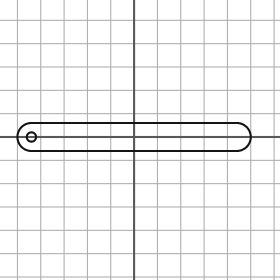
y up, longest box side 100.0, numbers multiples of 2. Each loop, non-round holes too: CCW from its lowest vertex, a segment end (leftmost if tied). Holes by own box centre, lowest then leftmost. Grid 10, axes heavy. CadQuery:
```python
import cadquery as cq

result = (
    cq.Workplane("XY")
    .moveTo(-44.0, -6.0)
    .lineTo(44.0, -6.0)
    .threePointArc((50.0, 0.0), (44.0, 6.0))
    .lineTo(-44.0, 6.0)
    .threePointArc((-50.0, 0.0), (-44.0, -6.0))
    .close()
    .moveTo(-44.0, 0.0)
    .circle(2.0)
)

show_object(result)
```